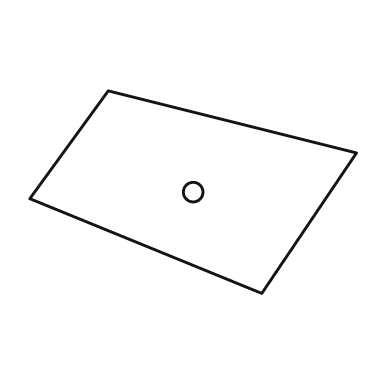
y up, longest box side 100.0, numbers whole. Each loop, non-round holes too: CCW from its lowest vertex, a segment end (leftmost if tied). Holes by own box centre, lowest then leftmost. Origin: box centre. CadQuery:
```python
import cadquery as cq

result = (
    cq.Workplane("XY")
    .moveTo(21.0, -31.0)
    .lineTo(50.0, 12.0)
    .lineTo(-26.0, 31.0)
    .lineTo(-50.0, -2.0)
    .close()
    .moveTo(0.0, 0.0)
    .circle(3.0)
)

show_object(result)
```